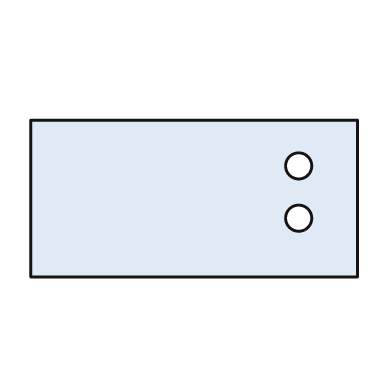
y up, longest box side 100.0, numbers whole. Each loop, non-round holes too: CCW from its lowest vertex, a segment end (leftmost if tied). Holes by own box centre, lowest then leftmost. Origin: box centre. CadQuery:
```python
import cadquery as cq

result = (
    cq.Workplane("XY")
    .moveTo(-50.0, -24.0)
    .lineTo(50.0, -24.0)
    .lineTo(50.0, 24.0)
    .lineTo(-50.0, 24.0)
    .close()
    .moveTo(32.0, -6.0)
    .circle(4.0)
    .moveTo(32.0, 10.0)
    .circle(4.0)
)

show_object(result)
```